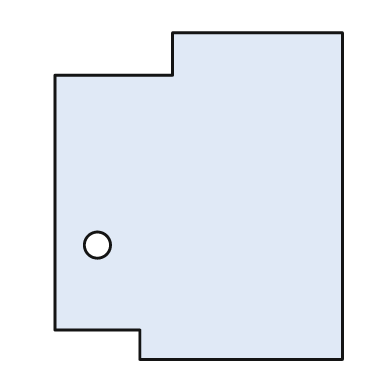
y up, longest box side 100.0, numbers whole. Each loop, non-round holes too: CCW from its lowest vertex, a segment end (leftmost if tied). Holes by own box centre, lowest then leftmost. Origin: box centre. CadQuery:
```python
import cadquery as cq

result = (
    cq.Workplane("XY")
    .moveTo(-18.0, -50.0)
    .lineTo(44.0, -50.0)
    .lineTo(44.0, 50.0)
    .lineTo(-8.0, 50.0)
    .lineTo(-8.0, 37.0)
    .lineTo(-44.0, 37.0)
    .lineTo(-44.0, -41.0)
    .lineTo(-18.0, -41.0)
    .close()
    .moveTo(-31.0, -15.0)
    .circle(4.0)
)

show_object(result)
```